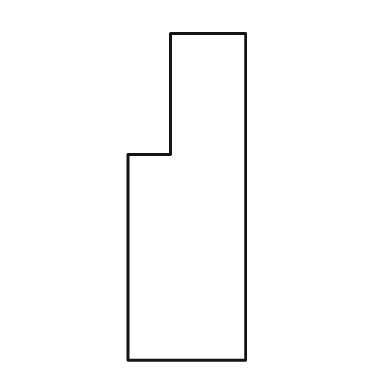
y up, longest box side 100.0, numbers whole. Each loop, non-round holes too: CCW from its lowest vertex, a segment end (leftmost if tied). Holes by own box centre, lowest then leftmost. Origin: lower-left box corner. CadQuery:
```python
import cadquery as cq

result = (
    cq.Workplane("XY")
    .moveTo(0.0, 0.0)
    .lineTo(36.0, 0.0)
    .lineTo(36.0, 100.0)
    .lineTo(13.0, 100.0)
    .lineTo(13.0, 63.0)
    .lineTo(0.0, 63.0)
    .close()
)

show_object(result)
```